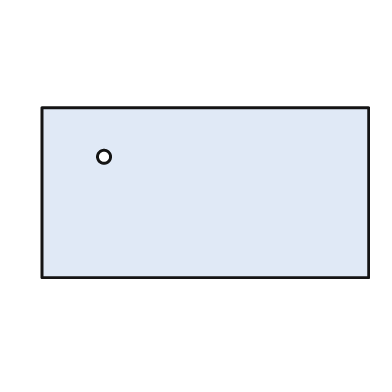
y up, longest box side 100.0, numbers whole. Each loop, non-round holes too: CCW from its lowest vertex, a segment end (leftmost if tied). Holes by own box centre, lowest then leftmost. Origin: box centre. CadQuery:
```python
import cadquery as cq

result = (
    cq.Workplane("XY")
    .moveTo(-50.0, -26.0)
    .lineTo(50.0, -26.0)
    .lineTo(50.0, 26.0)
    .lineTo(-50.0, 26.0)
    .close()
    .moveTo(-31.0, 11.0)
    .circle(2.0)
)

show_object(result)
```